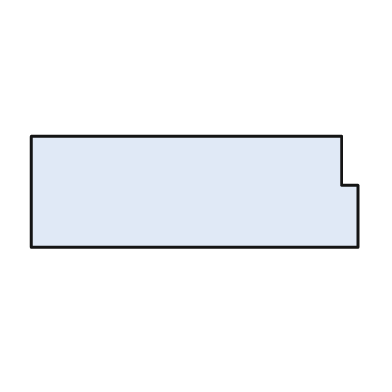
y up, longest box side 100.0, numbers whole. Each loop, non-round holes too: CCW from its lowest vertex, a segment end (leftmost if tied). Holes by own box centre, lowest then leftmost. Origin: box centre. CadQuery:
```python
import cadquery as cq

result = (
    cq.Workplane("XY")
    .moveTo(-50.0, -17.0)
    .lineTo(50.0, -17.0)
    .lineTo(50.0, 2.0)
    .lineTo(45.0, 2.0)
    .lineTo(45.0, 17.0)
    .lineTo(-50.0, 17.0)
    .close()
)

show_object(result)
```